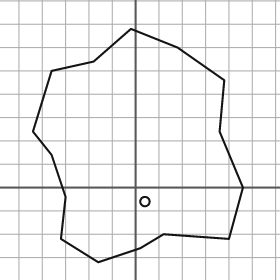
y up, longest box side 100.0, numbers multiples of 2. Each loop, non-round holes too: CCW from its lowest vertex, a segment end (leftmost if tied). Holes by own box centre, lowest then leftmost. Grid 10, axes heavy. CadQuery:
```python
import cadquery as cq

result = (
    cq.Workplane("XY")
    .moveTo(-16.0, -32.0)
    .lineTo(2.0, -26.0)
    .lineTo(12.0, -20.0)
    .lineTo(40.0, -22.0)
    .lineTo(46.0, 0.0)
    .lineTo(36.0, 24.0)
    .lineTo(38.0, 46.0)
    .lineTo(18.0, 60.0)
    .lineTo(-2.0, 68.0)
    .lineTo(-18.0, 54.0)
    .lineTo(-36.0, 50.0)
    .lineTo(-44.0, 24.0)
    .lineTo(-36.0, 14.0)
    .lineTo(-30.0, -4.0)
    .lineTo(-32.0, -22.0)
    .close()
    .moveTo(4.0, -6.0)
    .circle(2.0)
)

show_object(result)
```